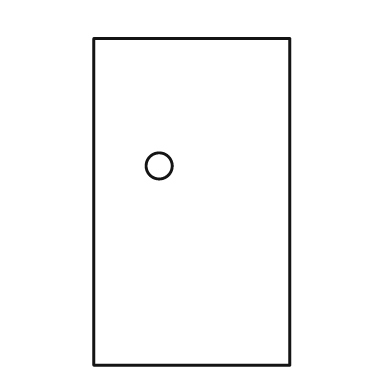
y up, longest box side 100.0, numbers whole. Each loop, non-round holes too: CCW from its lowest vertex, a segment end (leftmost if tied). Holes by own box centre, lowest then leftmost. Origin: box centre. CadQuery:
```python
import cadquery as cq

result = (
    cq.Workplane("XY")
    .moveTo(-30.0, -50.0)
    .lineTo(30.0, -50.0)
    .lineTo(30.0, 50.0)
    .lineTo(-30.0, 50.0)
    .close()
    .moveTo(-10.0, 11.0)
    .circle(4.0)
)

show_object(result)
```